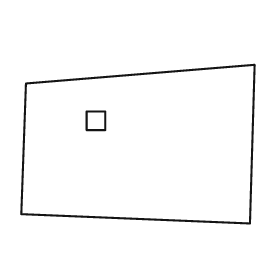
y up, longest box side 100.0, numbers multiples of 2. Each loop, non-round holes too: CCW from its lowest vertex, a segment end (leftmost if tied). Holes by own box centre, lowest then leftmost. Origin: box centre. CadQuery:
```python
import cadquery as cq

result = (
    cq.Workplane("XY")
    .moveTo(48.0, -34.0)
    .lineTo(50.0, 34.0)
    .lineTo(-48.0, 26.0)
    .lineTo(-50.0, -30.0)
    .close()
    .moveTo(-22.0, 6.0)
    .lineTo(-14.0, 6.0)
    .lineTo(-14.0, 14.0)
    .lineTo(-22.0, 14.0)
    .close()
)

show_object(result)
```